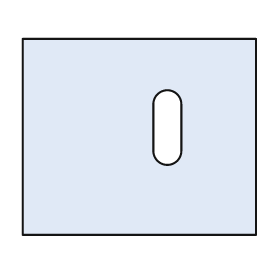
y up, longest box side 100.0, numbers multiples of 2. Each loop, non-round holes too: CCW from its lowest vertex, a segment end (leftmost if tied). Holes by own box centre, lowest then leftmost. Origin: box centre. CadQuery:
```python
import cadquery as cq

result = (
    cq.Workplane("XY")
    .moveTo(-50.0, -42.0)
    .lineTo(50.0, -42.0)
    .lineTo(50.0, 42.0)
    .lineTo(-50.0, 42.0)
    .close()
    .moveTo(6.0, -6.0)
    .threePointArc((12.0, -12.0), (18.0, -6.0))
    .lineTo(18.0, 14.0)
    .threePointArc((12.0, 20.0), (6.0, 14.0))
    .close()
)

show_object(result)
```